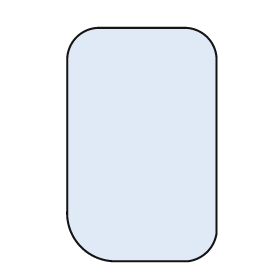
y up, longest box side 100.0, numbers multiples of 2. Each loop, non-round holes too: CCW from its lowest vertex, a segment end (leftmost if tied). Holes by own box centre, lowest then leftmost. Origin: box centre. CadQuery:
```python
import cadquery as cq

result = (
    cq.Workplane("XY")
    .moveTo(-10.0, -50.0)
    .lineTo(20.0, -50.0)
    .threePointArc((28.0, -46.0), (32.0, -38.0))
    .lineTo(32.0, 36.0)
    .threePointArc((28.0, 46.0), (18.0, 50.0))
    .lineTo(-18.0, 50.0)
    .threePointArc((-28.0, 46.0), (-32.0, 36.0))
    .lineTo(-32.0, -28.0)
    .threePointArc((-26.0, -44.0), (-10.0, -50.0))
    .close()
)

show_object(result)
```